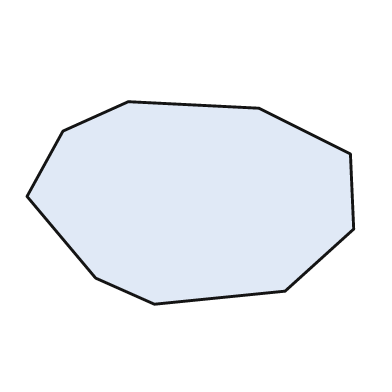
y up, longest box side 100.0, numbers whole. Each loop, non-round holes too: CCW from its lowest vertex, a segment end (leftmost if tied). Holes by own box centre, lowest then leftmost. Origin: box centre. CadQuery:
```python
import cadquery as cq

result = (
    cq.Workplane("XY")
    .moveTo(-11.0, -31.0)
    .lineTo(29.0, -27.0)
    .lineTo(50.0, -8.0)
    .lineTo(49.0, 15.0)
    .lineTo(21.0, 29.0)
    .lineTo(-19.0, 31.0)
    .lineTo(-39.0, 22.0)
    .lineTo(-50.0, 2.0)
    .lineTo(-29.0, -23.0)
    .close()
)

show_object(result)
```